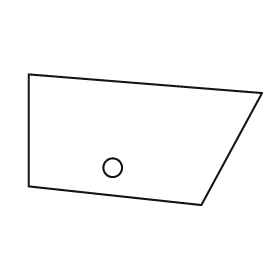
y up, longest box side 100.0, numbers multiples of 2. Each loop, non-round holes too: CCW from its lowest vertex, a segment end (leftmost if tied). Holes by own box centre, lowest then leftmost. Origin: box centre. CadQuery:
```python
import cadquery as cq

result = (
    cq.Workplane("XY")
    .moveTo(24.0, -28.0)
    .lineTo(50.0, 20.0)
    .lineTo(-50.0, 28.0)
    .lineTo(-50.0, -20.0)
    .close()
    .moveTo(-14.0, -12.0)
    .circle(4.0)
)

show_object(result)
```